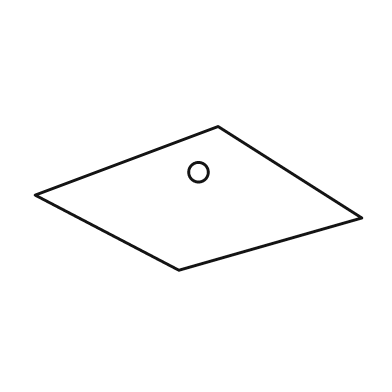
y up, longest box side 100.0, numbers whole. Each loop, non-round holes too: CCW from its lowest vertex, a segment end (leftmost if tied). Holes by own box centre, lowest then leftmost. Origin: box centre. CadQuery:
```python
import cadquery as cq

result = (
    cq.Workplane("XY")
    .moveTo(-6.0, -22.0)
    .lineTo(50.0, -6.0)
    .lineTo(6.0, 22.0)
    .lineTo(-50.0, 1.0)
    .close()
    .moveTo(0.0, 8.0)
    .circle(3.0)
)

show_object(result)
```